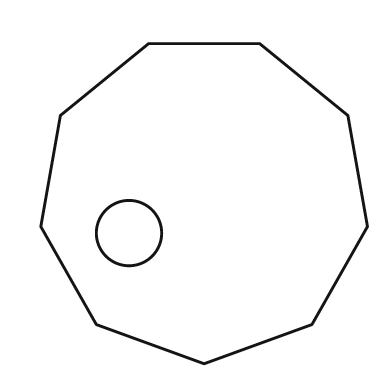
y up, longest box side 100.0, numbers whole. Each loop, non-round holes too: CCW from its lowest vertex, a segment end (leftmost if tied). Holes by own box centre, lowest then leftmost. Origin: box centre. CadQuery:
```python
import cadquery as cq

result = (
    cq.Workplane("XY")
    .moveTo(0.0, -49.0)
    .lineTo(33.0, -37.0)
    .lineTo(50.0, -7.0)
    .lineTo(44.0, 27.0)
    .lineTo(17.0, 49.0)
    .lineTo(-17.0, 49.0)
    .lineTo(-44.0, 27.0)
    .lineTo(-50.0, -7.0)
    .lineTo(-33.0, -37.0)
    .close()
    .moveTo(-23.0, -9.0)
    .circle(10.0)
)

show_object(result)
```